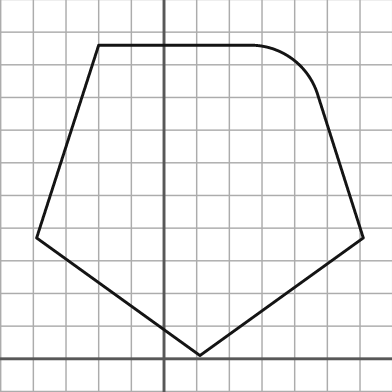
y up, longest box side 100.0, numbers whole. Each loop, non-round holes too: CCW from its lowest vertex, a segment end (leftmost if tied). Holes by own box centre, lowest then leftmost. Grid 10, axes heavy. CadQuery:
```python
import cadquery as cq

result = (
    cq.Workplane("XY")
    .moveTo(11.0, 1.0)
    .lineTo(61.0, 37.0)
    .lineTo(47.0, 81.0)
    .threePointArc((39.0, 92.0), (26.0, 96.0))
    .lineTo(-20.0, 96.0)
    .lineTo(-39.0, 37.0)
    .close()
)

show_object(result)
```